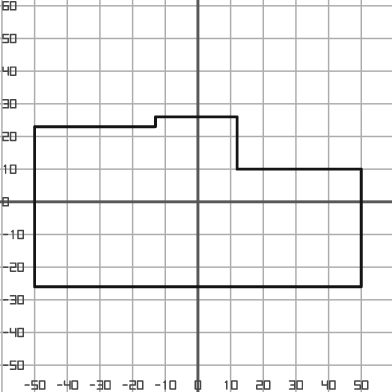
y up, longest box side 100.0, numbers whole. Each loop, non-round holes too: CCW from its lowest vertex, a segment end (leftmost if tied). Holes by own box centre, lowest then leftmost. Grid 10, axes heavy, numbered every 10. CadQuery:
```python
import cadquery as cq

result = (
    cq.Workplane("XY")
    .moveTo(-50.0, -26.0)
    .lineTo(50.0, -26.0)
    .lineTo(50.0, 10.0)
    .lineTo(12.0, 10.0)
    .lineTo(12.0, 26.0)
    .lineTo(-13.0, 26.0)
    .lineTo(-13.0, 23.0)
    .lineTo(-50.0, 23.0)
    .close()
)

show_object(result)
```